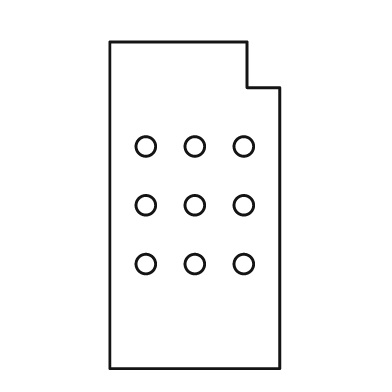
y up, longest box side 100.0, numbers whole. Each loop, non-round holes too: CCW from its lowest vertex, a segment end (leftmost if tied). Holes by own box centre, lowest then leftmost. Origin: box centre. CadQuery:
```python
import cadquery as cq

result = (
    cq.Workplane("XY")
    .moveTo(-26.0, -50.0)
    .lineTo(26.0, -50.0)
    .lineTo(26.0, 36.0)
    .lineTo(16.0, 36.0)
    .lineTo(16.0, 50.0)
    .lineTo(-26.0, 50.0)
    .close()
    .moveTo(-15.0, -18.0)
    .circle(3.0)
    .moveTo(0.0, -18.0)
    .circle(3.0)
    .moveTo(15.0, -18.0)
    .circle(3.0)
    .moveTo(-15.0, 0.0)
    .circle(3.0)
    .moveTo(0.0, 0.0)
    .circle(3.0)
    .moveTo(15.0, 0.0)
    .circle(3.0)
    .moveTo(-15.0, 18.0)
    .circle(3.0)
    .moveTo(0.0, 18.0)
    .circle(3.0)
    .moveTo(15.0, 18.0)
    .circle(3.0)
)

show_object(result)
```